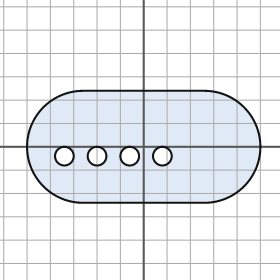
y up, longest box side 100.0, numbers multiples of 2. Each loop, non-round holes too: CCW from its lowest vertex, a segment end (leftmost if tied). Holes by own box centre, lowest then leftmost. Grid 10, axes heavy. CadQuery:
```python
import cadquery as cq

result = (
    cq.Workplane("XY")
    .moveTo(-26.0, -24.0)
    .lineTo(26.0, -24.0)
    .threePointArc((50.0, 0.0), (26.0, 24.0))
    .lineTo(-26.0, 24.0)
    .threePointArc((-50.0, 0.0), (-26.0, -24.0))
    .close()
    .moveTo(-34.0, -4.0)
    .circle(4.0)
    .moveTo(-20.0, -4.0)
    .circle(4.0)
    .moveTo(-6.0, -4.0)
    .circle(4.0)
    .moveTo(8.0, -4.0)
    .circle(4.0)
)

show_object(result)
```